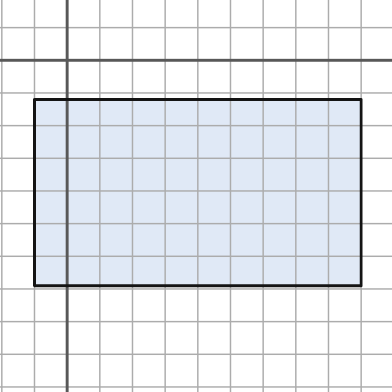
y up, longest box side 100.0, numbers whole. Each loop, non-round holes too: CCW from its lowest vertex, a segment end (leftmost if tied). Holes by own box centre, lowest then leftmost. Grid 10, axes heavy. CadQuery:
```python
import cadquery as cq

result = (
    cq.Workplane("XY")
    .moveTo(-10.0, -69.0)
    .lineTo(90.0, -69.0)
    .lineTo(90.0, -12.0)
    .lineTo(-10.0, -12.0)
    .close()
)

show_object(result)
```